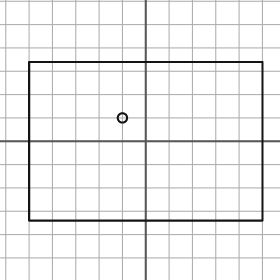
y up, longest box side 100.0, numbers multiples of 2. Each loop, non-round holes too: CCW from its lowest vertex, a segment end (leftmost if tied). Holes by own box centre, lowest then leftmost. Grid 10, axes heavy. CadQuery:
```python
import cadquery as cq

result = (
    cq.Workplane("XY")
    .moveTo(-50.0, -34.0)
    .lineTo(50.0, -34.0)
    .lineTo(50.0, 34.0)
    .lineTo(-50.0, 34.0)
    .close()
    .moveTo(-10.0, 10.0)
    .circle(2.0)
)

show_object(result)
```